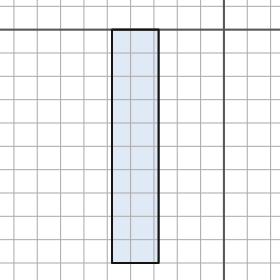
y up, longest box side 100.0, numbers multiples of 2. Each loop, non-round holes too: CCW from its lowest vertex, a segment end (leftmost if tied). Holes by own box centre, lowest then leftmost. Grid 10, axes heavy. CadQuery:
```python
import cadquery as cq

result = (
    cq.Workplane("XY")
    .moveTo(-48.0, -100.0)
    .lineTo(-28.0, -100.0)
    .lineTo(-28.0, 0.0)
    .lineTo(-48.0, 0.0)
    .close()
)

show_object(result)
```